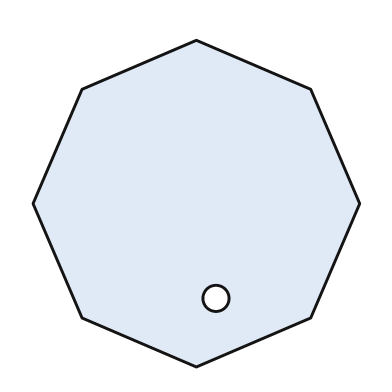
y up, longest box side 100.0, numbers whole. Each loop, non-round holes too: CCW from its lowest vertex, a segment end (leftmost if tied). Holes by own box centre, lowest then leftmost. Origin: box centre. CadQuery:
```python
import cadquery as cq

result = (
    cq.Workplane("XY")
    .moveTo(0.0, -50.0)
    .lineTo(35.0, -35.0)
    .lineTo(50.0, 0.0)
    .lineTo(35.0, 35.0)
    .lineTo(0.0, 50.0)
    .lineTo(-35.0, 35.0)
    .lineTo(-50.0, 0.0)
    .lineTo(-35.0, -35.0)
    .close()
    .moveTo(6.0, -29.0)
    .circle(4.0)
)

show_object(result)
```